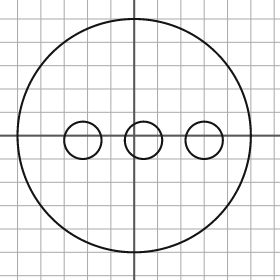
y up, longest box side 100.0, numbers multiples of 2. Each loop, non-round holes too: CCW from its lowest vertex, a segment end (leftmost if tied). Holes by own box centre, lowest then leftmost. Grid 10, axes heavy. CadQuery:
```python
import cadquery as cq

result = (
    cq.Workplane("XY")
    .moveTo(0.0, 0.0)
    .circle(50.0)
    .moveTo(-22.0, -2.0)
    .circle(8.0)
    .moveTo(4.0, -2.0)
    .circle(8.0)
    .moveTo(30.0, -2.0)
    .circle(8.0)
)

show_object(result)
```